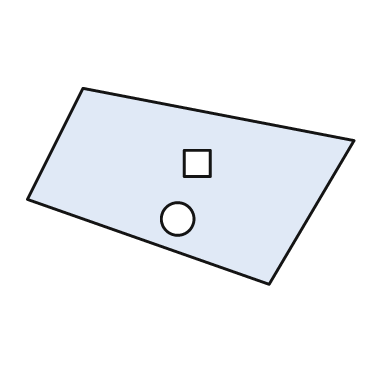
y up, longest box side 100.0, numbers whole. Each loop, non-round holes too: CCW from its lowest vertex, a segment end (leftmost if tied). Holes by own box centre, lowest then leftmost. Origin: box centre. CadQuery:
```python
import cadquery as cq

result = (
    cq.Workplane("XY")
    .moveTo(24.0, -30.0)
    .lineTo(50.0, 14.0)
    .lineTo(-33.0, 30.0)
    .lineTo(-50.0, -4.0)
    .close()
    .moveTo(-4.0, -10.0)
    .circle(5.0)
    .moveTo(-2.0, 3.0)
    .lineTo(6.0, 3.0)
    .lineTo(6.0, 11.0)
    .lineTo(-2.0, 11.0)
    .close()
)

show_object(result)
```